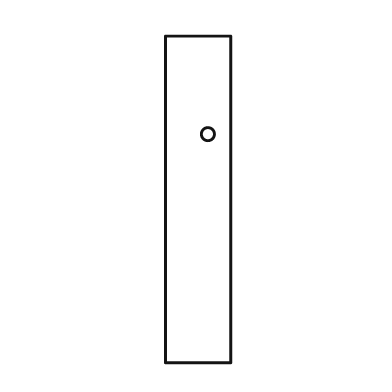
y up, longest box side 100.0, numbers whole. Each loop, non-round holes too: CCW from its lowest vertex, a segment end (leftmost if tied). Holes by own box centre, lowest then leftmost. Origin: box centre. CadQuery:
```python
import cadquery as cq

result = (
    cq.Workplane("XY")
    .moveTo(-10.0, -50.0)
    .lineTo(10.0, -50.0)
    .lineTo(10.0, 50.0)
    .lineTo(-10.0, 50.0)
    .close()
    .moveTo(3.0, 20.0)
    .circle(2.0)
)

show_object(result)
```